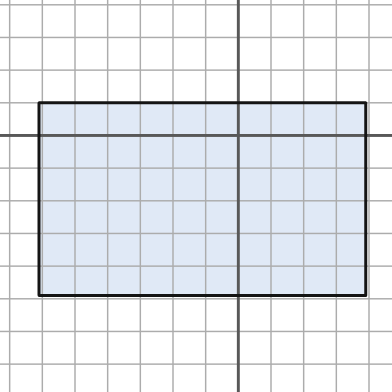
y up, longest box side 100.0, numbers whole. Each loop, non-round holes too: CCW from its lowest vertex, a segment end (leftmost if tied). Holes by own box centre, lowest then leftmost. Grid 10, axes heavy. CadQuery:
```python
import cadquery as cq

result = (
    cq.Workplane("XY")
    .moveTo(-61.0, -49.0)
    .lineTo(39.0, -49.0)
    .lineTo(39.0, 10.0)
    .lineTo(-61.0, 10.0)
    .close()
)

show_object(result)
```